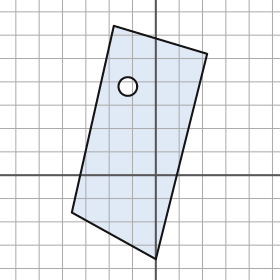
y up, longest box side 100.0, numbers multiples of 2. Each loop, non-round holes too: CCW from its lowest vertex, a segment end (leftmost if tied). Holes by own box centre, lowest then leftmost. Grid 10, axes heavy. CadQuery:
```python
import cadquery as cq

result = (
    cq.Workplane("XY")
    .moveTo(0.0, -36.0)
    .lineTo(22.0, 52.0)
    .lineTo(-18.0, 64.0)
    .lineTo(-36.0, -16.0)
    .close()
    .moveTo(-12.0, 38.0)
    .circle(4.0)
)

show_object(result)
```